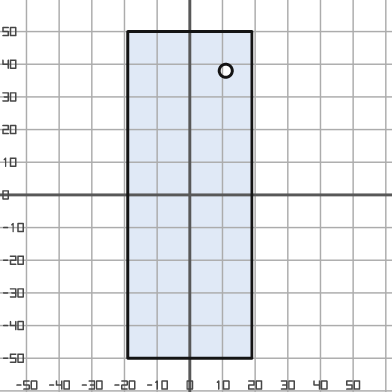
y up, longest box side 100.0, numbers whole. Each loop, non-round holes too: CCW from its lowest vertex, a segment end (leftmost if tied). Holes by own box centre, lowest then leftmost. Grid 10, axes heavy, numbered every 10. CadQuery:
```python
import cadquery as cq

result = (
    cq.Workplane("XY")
    .moveTo(-19.0, -50.0)
    .lineTo(19.0, -50.0)
    .lineTo(19.0, 50.0)
    .lineTo(-19.0, 50.0)
    .close()
    .moveTo(11.0, 38.0)
    .circle(2.0)
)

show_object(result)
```